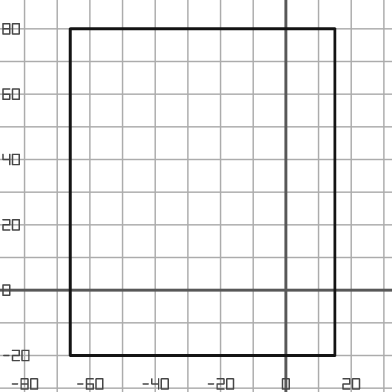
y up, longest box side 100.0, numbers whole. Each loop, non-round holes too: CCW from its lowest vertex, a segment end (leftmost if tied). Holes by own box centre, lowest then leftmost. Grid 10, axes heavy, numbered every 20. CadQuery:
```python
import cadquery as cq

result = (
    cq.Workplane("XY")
    .moveTo(-66.0, -20.0)
    .lineTo(15.0, -20.0)
    .lineTo(15.0, 80.0)
    .lineTo(-66.0, 80.0)
    .close()
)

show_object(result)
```